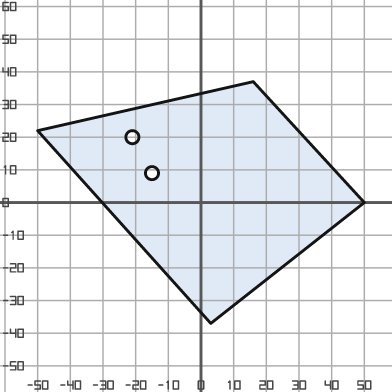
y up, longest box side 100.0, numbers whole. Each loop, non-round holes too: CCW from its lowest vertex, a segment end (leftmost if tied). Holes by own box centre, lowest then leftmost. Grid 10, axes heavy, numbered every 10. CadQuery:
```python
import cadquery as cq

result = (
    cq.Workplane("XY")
    .moveTo(3.0, -37.0)
    .lineTo(50.0, 0.0)
    .lineTo(16.0, 37.0)
    .lineTo(-50.0, 22.0)
    .close()
    .moveTo(-15.0, 9.0)
    .circle(2.0)
    .moveTo(-21.0, 20.0)
    .circle(2.0)
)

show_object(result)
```